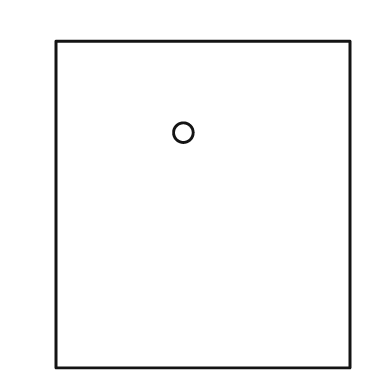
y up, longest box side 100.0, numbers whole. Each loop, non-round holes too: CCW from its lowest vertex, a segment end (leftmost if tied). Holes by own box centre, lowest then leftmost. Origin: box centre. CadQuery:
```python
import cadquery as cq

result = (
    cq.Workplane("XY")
    .moveTo(-45.0, -50.0)
    .lineTo(45.0, -50.0)
    .lineTo(45.0, 50.0)
    .lineTo(-45.0, 50.0)
    .close()
    .moveTo(-6.0, 22.0)
    .circle(3.0)
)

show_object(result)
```